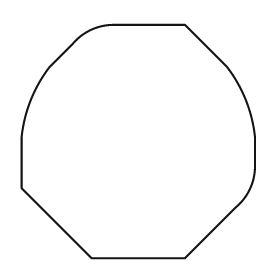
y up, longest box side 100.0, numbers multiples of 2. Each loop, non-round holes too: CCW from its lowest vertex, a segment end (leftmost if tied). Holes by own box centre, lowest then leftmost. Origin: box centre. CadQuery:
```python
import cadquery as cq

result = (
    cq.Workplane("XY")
    .moveTo(-20.0, -50.0)
    .lineTo(20.0, -50.0)
    .lineTo(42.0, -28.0)
    .threePointArc((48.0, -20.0), (50.0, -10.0))
    .lineTo(50.0, 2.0)
    .threePointArc((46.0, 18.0), (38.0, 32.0))
    .lineTo(20.0, 50.0)
    .lineTo(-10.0, 50.0)
    .threePointArc((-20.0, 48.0), (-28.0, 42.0))
    .lineTo(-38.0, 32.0)
    .threePointArc((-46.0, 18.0), (-50.0, 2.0))
    .lineTo(-50.0, -20.0)
    .close()
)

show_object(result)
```